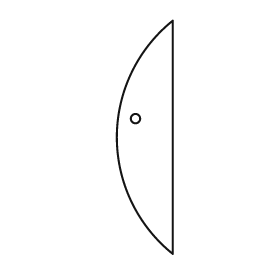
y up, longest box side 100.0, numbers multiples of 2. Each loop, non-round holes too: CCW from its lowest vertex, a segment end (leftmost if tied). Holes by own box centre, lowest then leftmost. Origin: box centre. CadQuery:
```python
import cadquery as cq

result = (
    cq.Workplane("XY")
    .moveTo(12.0, -50.0)
    .lineTo(12.0, 50.0)
    .threePointArc((-12.0, 0.0), (12.0, -50.0))
    .close()
    .moveTo(-4.0, 8.0)
    .circle(2.0)
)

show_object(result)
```